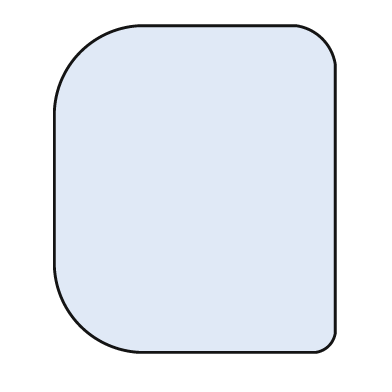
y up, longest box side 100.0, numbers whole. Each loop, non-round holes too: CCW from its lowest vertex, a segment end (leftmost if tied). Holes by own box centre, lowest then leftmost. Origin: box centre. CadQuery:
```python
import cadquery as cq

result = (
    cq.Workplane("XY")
    .moveTo(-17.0, -50.0)
    .lineTo(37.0, -50.0)
    .threePointArc((41.0, -48.0), (43.0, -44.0))
    .lineTo(43.0, 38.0)
    .threePointArc((39.0, 46.0), (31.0, 50.0))
    .lineTo(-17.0, 50.0)
    .threePointArc((-35.0, 42.0), (-43.0, 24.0))
    .lineTo(-43.0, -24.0)
    .threePointArc((-35.0, -42.0), (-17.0, -50.0))
    .close()
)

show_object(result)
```